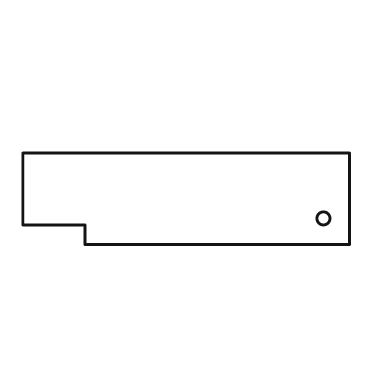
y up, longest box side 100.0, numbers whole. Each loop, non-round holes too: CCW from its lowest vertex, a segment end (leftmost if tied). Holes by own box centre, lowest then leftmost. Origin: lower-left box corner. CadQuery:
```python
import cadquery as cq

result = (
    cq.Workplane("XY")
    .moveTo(19.0, 0.0)
    .lineTo(100.0, 0.0)
    .lineTo(100.0, 28.0)
    .lineTo(0.0, 28.0)
    .lineTo(0.0, 6.0)
    .lineTo(19.0, 6.0)
    .close()
    .moveTo(92.0, 8.0)
    .circle(2.0)
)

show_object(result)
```